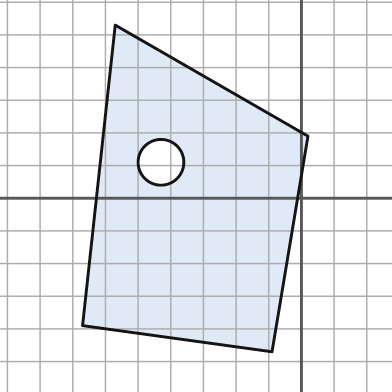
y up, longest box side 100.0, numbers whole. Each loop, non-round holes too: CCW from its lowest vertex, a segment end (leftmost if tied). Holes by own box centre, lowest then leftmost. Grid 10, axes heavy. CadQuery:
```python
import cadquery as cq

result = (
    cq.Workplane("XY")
    .moveTo(-9.0, -47.0)
    .lineTo(2.0, 19.0)
    .lineTo(-57.0, 53.0)
    .lineTo(-67.0, -39.0)
    .close()
    .moveTo(-43.0, 11.0)
    .circle(7.0)
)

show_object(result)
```